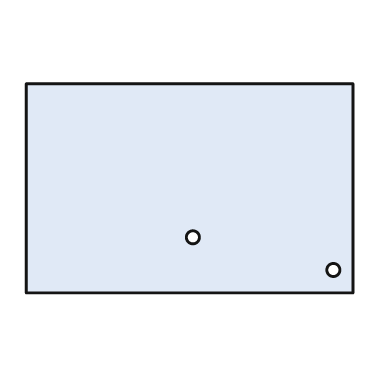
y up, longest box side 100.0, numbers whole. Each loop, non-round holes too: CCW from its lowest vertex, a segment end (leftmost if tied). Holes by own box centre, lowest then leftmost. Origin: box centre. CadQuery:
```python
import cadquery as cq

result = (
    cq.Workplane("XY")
    .moveTo(-50.0, -32.0)
    .lineTo(50.0, -32.0)
    .lineTo(50.0, 32.0)
    .lineTo(-50.0, 32.0)
    .close()
    .moveTo(44.0, -25.0)
    .circle(2.0)
    .moveTo(1.0, -15.0)
    .circle(2.0)
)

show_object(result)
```